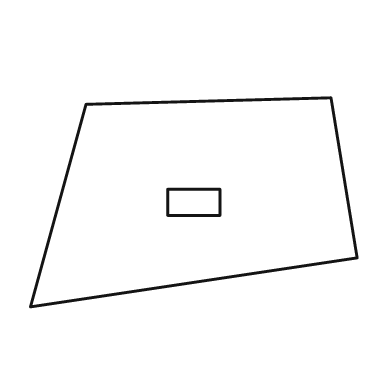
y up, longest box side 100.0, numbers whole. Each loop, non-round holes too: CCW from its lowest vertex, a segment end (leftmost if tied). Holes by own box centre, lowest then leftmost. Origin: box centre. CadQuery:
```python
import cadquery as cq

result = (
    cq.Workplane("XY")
    .moveTo(-50.0, -32.0)
    .lineTo(50.0, -17.0)
    .lineTo(42.0, 32.0)
    .lineTo(-33.0, 30.0)
    .close()
    .moveTo(-8.0, -4.0)
    .lineTo(8.0, -4.0)
    .lineTo(8.0, 4.0)
    .lineTo(-8.0, 4.0)
    .close()
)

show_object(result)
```